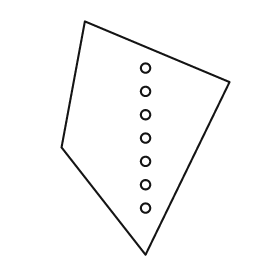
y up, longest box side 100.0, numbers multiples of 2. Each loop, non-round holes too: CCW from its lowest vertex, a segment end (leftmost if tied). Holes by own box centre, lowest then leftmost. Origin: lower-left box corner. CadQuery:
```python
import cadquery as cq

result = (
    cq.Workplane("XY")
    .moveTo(36.0, 0.0)
    .lineTo(72.0, 74.0)
    .lineTo(10.0, 100.0)
    .lineTo(0.0, 46.0)
    .close()
    .moveTo(36.0, 20.0)
    .circle(2.0)
    .moveTo(36.0, 30.0)
    .circle(2.0)
    .moveTo(36.0, 40.0)
    .circle(2.0)
    .moveTo(36.0, 50.0)
    .circle(2.0)
    .moveTo(36.0, 60.0)
    .circle(2.0)
    .moveTo(36.0, 70.0)
    .circle(2.0)
    .moveTo(36.0, 80.0)
    .circle(2.0)
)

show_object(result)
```